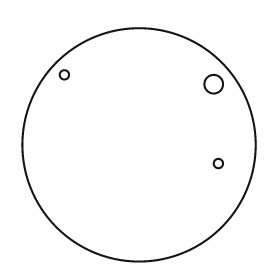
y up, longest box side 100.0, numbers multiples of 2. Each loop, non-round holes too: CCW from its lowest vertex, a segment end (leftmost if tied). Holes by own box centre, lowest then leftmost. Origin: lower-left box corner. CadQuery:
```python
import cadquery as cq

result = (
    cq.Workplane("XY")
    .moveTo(50.0, 50.0)
    .circle(50.0)
    .moveTo(84.0, 42.0)
    .circle(2.0)
    .moveTo(82.0, 76.0)
    .circle(4.0)
    .moveTo(18.0, 80.0)
    .circle(2.0)
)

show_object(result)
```